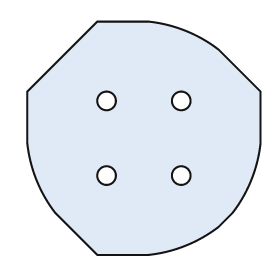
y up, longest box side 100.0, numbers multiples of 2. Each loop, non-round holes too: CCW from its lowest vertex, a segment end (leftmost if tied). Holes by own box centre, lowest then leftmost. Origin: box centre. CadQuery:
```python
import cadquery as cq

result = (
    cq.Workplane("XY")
    .moveTo(-20.0, -50.0)
    .lineTo(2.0, -50.0)
    .threePointArc((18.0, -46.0), (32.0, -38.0))
    .lineTo(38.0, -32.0)
    .threePointArc((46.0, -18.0), (50.0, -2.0))
    .lineTo(50.0, 20.0)
    .lineTo(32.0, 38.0)
    .threePointArc((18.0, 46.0), (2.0, 50.0))
    .lineTo(-20.0, 50.0)
    .lineTo(-50.0, 20.0)
    .lineTo(-50.0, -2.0)
    .threePointArc((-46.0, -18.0), (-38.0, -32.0))
    .close()
    .moveTo(-16.0, -16.0)
    .circle(4.0)
    .moveTo(16.0, -16.0)
    .circle(4.0)
    .moveTo(-16.0, 16.0)
    .circle(4.0)
    .moveTo(16.0, 16.0)
    .circle(4.0)
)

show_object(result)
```